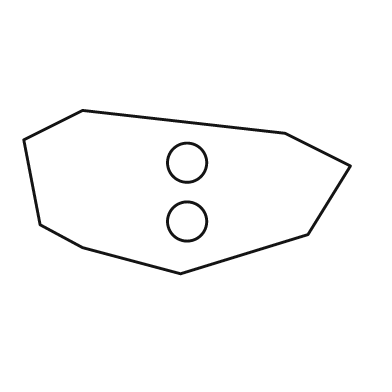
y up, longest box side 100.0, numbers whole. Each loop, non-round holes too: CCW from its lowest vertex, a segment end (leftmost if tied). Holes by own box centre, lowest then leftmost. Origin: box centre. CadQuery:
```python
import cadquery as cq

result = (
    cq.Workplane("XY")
    .moveTo(-2.0, -25.0)
    .lineTo(37.0, -13.0)
    .lineTo(50.0, 8.0)
    .lineTo(30.0, 18.0)
    .lineTo(-32.0, 25.0)
    .lineTo(-50.0, 16.0)
    .lineTo(-45.0, -10.0)
    .lineTo(-32.0, -17.0)
    .close()
    .moveTo(0.0, -9.0)
    .circle(6.0)
    .moveTo(0.0, 9.0)
    .circle(6.0)
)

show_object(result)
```